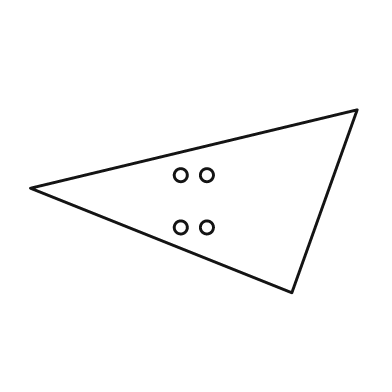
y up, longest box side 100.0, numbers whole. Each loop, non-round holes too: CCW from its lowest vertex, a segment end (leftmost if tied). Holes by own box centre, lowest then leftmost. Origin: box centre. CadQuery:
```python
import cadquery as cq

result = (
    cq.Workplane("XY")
    .moveTo(30.0, -28.0)
    .lineTo(50.0, 28.0)
    .lineTo(-50.0, 4.0)
    .close()
    .moveTo(-4.0, -8.0)
    .circle(2.0)
    .moveTo(4.0, -8.0)
    .circle(2.0)
    .moveTo(-4.0, 8.0)
    .circle(2.0)
    .moveTo(4.0, 8.0)
    .circle(2.0)
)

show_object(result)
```